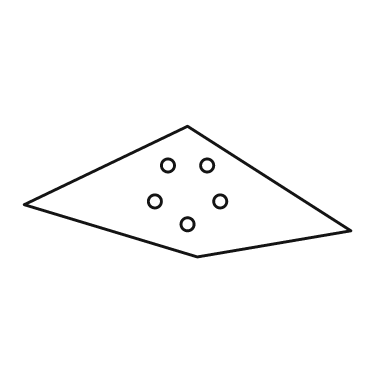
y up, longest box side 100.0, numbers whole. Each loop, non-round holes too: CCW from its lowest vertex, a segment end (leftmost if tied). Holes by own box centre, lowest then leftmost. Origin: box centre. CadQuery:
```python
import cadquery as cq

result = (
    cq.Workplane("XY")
    .moveTo(3.0, -20.0)
    .lineTo(50.0, -12.0)
    .lineTo(0.0, 20.0)
    .lineTo(-50.0, -4.0)
    .close()
    .moveTo(0.0, -10.0)
    .circle(2.0)
    .moveTo(-10.0, -3.0)
    .circle(2.0)
    .moveTo(10.0, -3.0)
    .circle(2.0)
    .moveTo(-6.0, 8.0)
    .circle(2.0)
    .moveTo(6.0, 8.0)
    .circle(2.0)
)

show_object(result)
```